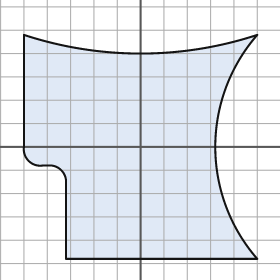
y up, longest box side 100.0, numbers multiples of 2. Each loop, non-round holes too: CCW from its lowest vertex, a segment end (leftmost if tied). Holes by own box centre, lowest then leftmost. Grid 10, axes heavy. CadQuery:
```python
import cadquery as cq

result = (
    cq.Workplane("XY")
    .moveTo(-32.0, -48.0)
    .lineTo(50.0, -48.0)
    .threePointArc((32.0, 0.0), (50.0, 48.0))
    .threePointArc((0.0, 40.0), (-50.0, 48.0))
    .lineTo(-50.0, 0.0)
    .threePointArc((-48.0, -6.0), (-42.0, -8.0))
    .lineTo(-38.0, -8.0)
    .threePointArc((-34.0, -10.0), (-32.0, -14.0))
    .close()
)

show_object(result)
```